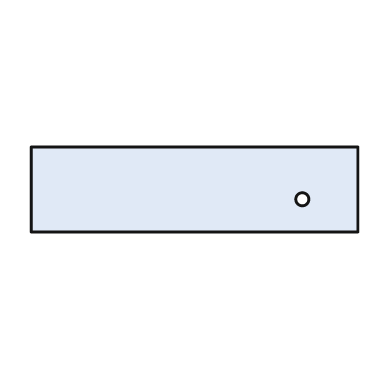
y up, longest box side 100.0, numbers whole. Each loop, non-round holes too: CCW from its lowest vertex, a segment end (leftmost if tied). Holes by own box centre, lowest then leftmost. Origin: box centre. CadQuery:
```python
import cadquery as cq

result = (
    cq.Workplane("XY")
    .moveTo(-50.0, -13.0)
    .lineTo(50.0, -13.0)
    .lineTo(50.0, 13.0)
    .lineTo(-50.0, 13.0)
    .close()
    .moveTo(33.0, -3.0)
    .circle(2.0)
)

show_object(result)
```